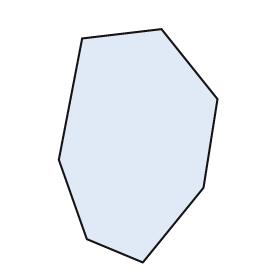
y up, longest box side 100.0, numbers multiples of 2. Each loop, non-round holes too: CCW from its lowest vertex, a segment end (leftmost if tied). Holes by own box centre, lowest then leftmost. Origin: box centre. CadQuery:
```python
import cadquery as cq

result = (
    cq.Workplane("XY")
    .moveTo(2.0, -50.0)
    .lineTo(28.0, -18.0)
    .lineTo(34.0, 20.0)
    .lineTo(10.0, 50.0)
    .lineTo(-24.0, 46.0)
    .lineTo(-34.0, -6.0)
    .lineTo(-22.0, -40.0)
    .close()
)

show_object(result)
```